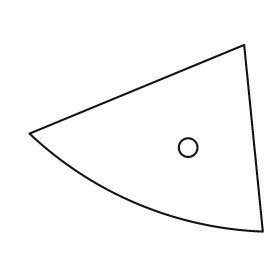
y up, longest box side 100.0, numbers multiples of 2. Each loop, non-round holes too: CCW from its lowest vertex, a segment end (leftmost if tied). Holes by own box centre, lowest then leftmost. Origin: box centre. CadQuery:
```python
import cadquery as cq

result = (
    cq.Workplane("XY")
    .moveTo(50.0, -40.0)
    .lineTo(42.0, 40.0)
    .lineTo(-50.0, 2.0)
    .threePointArc((-4.0, -28.0), (50.0, -40.0))
    .close()
    .moveTo(18.0, -4.0)
    .circle(4.0)
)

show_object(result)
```